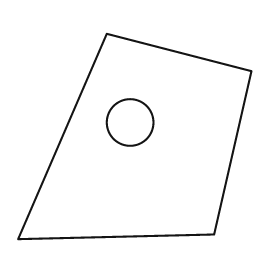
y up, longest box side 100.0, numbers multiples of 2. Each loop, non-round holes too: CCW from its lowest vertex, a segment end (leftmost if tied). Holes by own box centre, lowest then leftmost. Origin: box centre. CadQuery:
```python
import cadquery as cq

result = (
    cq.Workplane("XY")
    .moveTo(-50.0, -44.0)
    .lineTo(34.0, -42.0)
    .lineTo(50.0, 28.0)
    .lineTo(-12.0, 44.0)
    .close()
    .moveTo(-2.0, 6.0)
    .circle(10.0)
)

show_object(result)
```